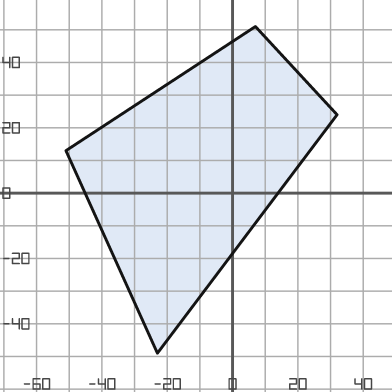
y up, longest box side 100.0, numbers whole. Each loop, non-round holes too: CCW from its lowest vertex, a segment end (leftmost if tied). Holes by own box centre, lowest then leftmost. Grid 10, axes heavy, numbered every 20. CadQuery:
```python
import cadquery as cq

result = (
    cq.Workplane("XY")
    .moveTo(-23.0, -49.0)
    .lineTo(32.0, 24.0)
    .lineTo(7.0, 51.0)
    .lineTo(-51.0, 13.0)
    .close()
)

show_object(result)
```